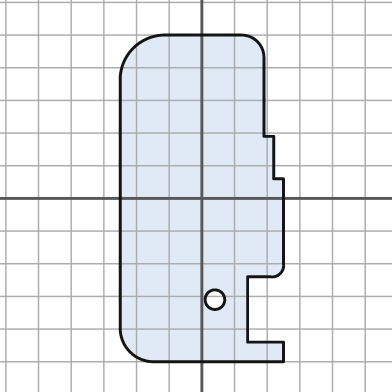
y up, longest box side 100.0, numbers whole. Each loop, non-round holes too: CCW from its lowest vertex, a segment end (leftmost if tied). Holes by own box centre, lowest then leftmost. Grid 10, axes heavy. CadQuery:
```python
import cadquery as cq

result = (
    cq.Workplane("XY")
    .moveTo(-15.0, -50.0)
    .lineTo(25.0, -50.0)
    .lineTo(25.0, -44.0)
    .lineTo(14.0, -44.0)
    .lineTo(14.0, -24.0)
    .lineTo(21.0, -24.0)
    .threePointArc((24.0, -23.0), (25.0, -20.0))
    .lineTo(25.0, 6.0)
    .lineTo(22.0, 6.0)
    .lineTo(22.0, 19.0)
    .lineTo(19.0, 19.0)
    .lineTo(19.0, 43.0)
    .threePointArc((17.0, 48.0), (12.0, 50.0))
    .lineTo(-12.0, 50.0)
    .threePointArc((-21.0, 46.0), (-25.0, 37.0))
    .lineTo(-25.0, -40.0)
    .threePointArc((-22.0, -47.0), (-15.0, -50.0))
    .close()
    .moveTo(4.0, -31.0)
    .circle(3.0)
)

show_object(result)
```